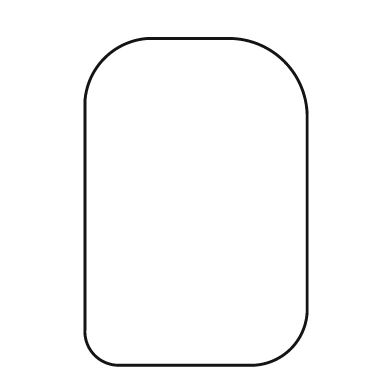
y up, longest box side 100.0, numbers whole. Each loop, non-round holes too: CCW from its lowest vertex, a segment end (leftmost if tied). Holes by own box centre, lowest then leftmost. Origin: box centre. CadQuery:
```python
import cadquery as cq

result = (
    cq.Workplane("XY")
    .moveTo(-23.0, -50.0)
    .lineTo(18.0, -50.0)
    .threePointArc((29.0, -45.0), (34.0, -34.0))
    .lineTo(34.0, 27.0)
    .threePointArc((27.0, 43.0), (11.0, 50.0))
    .lineTo(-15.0, 50.0)
    .threePointArc((-28.0, 44.0), (-34.0, 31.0))
    .lineTo(-34.0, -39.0)
    .threePointArc((-31.0, -47.0), (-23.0, -50.0))
    .close()
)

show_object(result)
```